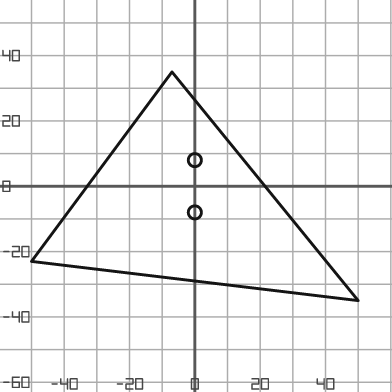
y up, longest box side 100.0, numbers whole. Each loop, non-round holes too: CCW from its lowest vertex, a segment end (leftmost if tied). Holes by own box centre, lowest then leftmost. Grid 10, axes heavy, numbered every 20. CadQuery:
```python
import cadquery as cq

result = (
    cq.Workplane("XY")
    .moveTo(50.0, -35.0)
    .lineTo(-7.0, 35.0)
    .lineTo(-50.0, -23.0)
    .close()
    .moveTo(0.0, -8.0)
    .circle(2.0)
    .moveTo(0.0, 8.0)
    .circle(2.0)
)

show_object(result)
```